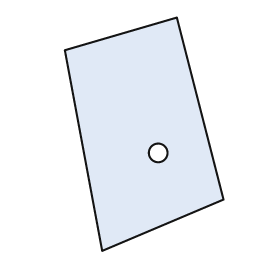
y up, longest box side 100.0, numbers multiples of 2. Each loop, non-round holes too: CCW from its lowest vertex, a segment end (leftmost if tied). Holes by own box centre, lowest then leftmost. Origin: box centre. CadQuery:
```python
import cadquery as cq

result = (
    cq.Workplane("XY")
    .moveTo(-18.0, -50.0)
    .lineTo(34.0, -28.0)
    .lineTo(14.0, 50.0)
    .lineTo(-34.0, 36.0)
    .close()
    .moveTo(6.0, -8.0)
    .circle(4.0)
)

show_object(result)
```